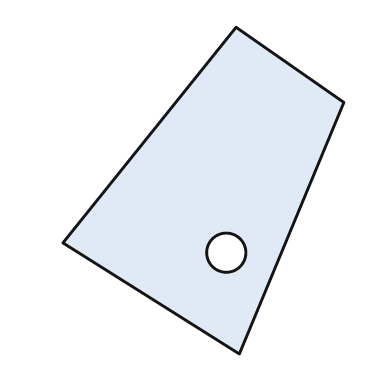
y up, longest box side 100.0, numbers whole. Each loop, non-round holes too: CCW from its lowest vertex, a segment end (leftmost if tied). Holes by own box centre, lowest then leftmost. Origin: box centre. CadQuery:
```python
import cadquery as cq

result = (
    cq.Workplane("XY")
    .moveTo(11.0, -50.0)
    .lineTo(43.0, 27.0)
    .lineTo(10.0, 50.0)
    .lineTo(-43.0, -16.0)
    .close()
    .moveTo(7.0, -19.0)
    .circle(6.0)
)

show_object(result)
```